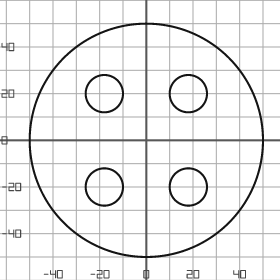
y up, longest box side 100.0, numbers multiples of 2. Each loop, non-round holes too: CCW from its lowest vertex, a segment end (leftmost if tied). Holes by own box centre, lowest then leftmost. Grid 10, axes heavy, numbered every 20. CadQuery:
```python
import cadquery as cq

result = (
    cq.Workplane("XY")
    .moveTo(0.0, 0.0)
    .circle(50.0)
    .moveTo(-18.0, -20.0)
    .circle(8.0)
    .moveTo(18.0, -20.0)
    .circle(8.0)
    .moveTo(-18.0, 20.0)
    .circle(8.0)
    .moveTo(18.0, 20.0)
    .circle(8.0)
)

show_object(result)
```